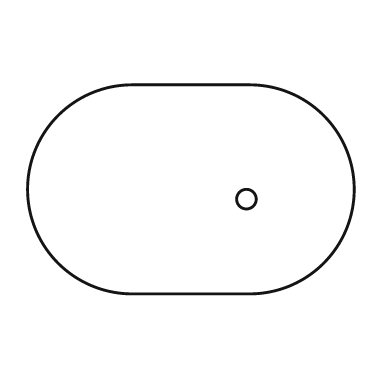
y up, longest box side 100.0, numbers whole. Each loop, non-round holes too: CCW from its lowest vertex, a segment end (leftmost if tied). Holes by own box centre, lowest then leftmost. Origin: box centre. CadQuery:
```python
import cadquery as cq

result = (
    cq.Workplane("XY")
    .moveTo(-18.0, -32.0)
    .lineTo(18.0, -32.0)
    .threePointArc((50.0, 0.0), (18.0, 32.0))
    .lineTo(-18.0, 32.0)
    .threePointArc((-50.0, 0.0), (-18.0, -32.0))
    .close()
    .moveTo(17.0, -3.0)
    .circle(3.0)
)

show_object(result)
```